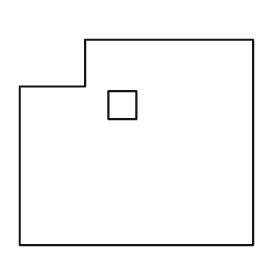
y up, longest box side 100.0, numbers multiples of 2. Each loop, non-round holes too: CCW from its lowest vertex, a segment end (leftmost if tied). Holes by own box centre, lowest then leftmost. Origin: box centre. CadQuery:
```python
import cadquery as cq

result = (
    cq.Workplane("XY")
    .moveTo(-50.0, -44.0)
    .lineTo(50.0, -44.0)
    .lineTo(50.0, 44.0)
    .lineTo(-22.0, 44.0)
    .lineTo(-22.0, 24.0)
    .lineTo(-50.0, 24.0)
    .close()
    .moveTo(-12.0, 10.0)
    .lineTo(0.0, 10.0)
    .lineTo(0.0, 22.0)
    .lineTo(-12.0, 22.0)
    .close()
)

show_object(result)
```